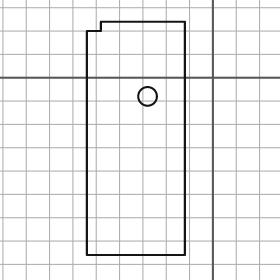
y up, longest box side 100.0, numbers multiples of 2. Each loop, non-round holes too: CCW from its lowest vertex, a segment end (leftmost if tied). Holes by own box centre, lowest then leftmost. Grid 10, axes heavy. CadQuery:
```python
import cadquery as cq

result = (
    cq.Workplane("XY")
    .moveTo(-54.0, -76.0)
    .lineTo(-12.0, -76.0)
    .lineTo(-12.0, 24.0)
    .lineTo(-48.0, 24.0)
    .lineTo(-48.0, 20.0)
    .lineTo(-54.0, 20.0)
    .close()
    .moveTo(-28.0, -8.0)
    .circle(4.0)
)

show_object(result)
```